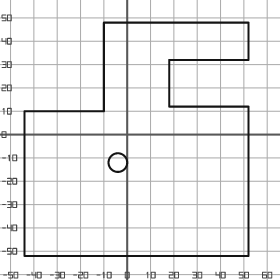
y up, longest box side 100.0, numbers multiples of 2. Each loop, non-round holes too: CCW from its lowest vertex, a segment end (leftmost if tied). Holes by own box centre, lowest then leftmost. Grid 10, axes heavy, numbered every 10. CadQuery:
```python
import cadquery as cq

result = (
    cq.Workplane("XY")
    .moveTo(-44.0, -52.0)
    .lineTo(52.0, -52.0)
    .lineTo(52.0, 12.0)
    .lineTo(18.0, 12.0)
    .lineTo(18.0, 32.0)
    .lineTo(52.0, 32.0)
    .lineTo(52.0, 48.0)
    .lineTo(-10.0, 48.0)
    .lineTo(-10.0, 10.0)
    .lineTo(-44.0, 10.0)
    .close()
    .moveTo(-4.0, -12.0)
    .circle(4.0)
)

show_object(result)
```